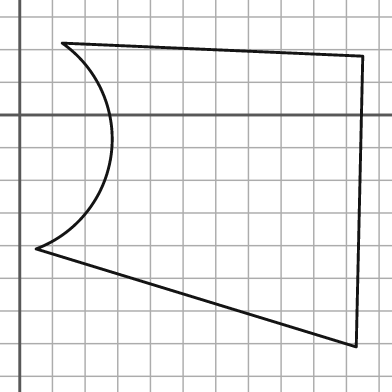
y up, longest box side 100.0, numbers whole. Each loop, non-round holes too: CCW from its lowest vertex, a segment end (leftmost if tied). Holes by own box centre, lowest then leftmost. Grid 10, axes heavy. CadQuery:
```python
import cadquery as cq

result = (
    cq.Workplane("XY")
    .moveTo(103.0, -71.0)
    .lineTo(105.0, 18.0)
    .lineTo(13.0, 22.0)
    .threePointArc((28.0, -12.0), (5.0, -41.0))
    .close()
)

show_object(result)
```